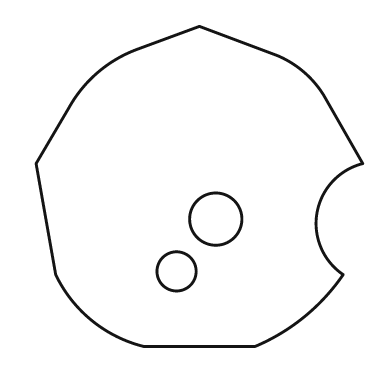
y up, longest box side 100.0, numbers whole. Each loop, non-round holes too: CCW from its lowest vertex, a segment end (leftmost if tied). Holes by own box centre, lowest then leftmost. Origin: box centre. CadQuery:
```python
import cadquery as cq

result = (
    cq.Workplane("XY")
    .moveTo(-17.0, -49.0)
    .lineTo(17.0, -49.0)
    .threePointArc((32.0, -40.0), (44.0, -27.0))
    .threePointArc((36.0, -8.0), (50.0, 7.0))
    .lineTo(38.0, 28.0)
    .threePointArc((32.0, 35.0), (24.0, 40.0))
    .lineTo(0.0, 49.0)
    .lineTo(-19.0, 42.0)
    .threePointArc((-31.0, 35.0), (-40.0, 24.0))
    .lineTo(-50.0, 7.0)
    .lineTo(-44.0, -27.0)
    .threePointArc((-33.0, -41.0), (-17.0, -49.0))
    .close()
    .moveTo(-7.0, -26.0)
    .circle(6.0)
    .moveTo(5.0, -10.0)
    .circle(8.0)
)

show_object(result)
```